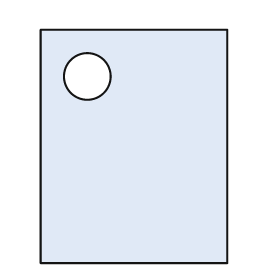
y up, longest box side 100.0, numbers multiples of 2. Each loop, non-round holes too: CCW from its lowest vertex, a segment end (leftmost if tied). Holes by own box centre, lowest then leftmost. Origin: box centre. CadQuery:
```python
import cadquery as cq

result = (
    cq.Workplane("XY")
    .moveTo(-40.0, -50.0)
    .lineTo(40.0, -50.0)
    .lineTo(40.0, 50.0)
    .lineTo(-40.0, 50.0)
    .close()
    .moveTo(-20.0, 30.0)
    .circle(10.0)
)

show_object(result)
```